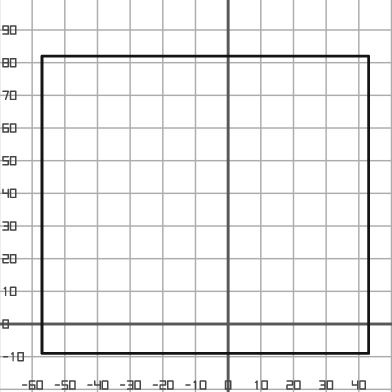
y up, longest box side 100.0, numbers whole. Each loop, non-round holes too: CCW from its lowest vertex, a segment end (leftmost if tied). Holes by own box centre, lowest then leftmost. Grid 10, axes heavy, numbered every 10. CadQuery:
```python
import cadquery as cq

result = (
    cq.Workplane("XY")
    .moveTo(-57.0, -9.0)
    .lineTo(43.0, -9.0)
    .lineTo(43.0, 82.0)
    .lineTo(-57.0, 82.0)
    .close()
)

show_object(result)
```